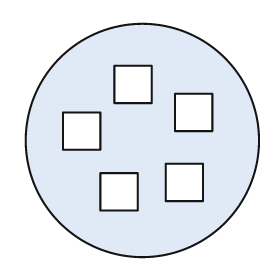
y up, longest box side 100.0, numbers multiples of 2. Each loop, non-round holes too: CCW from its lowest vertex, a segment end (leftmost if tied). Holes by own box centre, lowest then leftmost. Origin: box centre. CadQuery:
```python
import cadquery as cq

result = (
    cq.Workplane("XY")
    .moveTo(0.0, 0.0)
    .circle(50.0)
    .moveTo(-18.0, -30.0)
    .lineTo(-2.0, -30.0)
    .lineTo(-2.0, -14.0)
    .lineTo(-18.0, -14.0)
    .close()
    .moveTo(10.0, -26.0)
    .lineTo(26.0, -26.0)
    .lineTo(26.0, -10.0)
    .lineTo(10.0, -10.0)
    .close()
    .moveTo(-34.0, -4.0)
    .lineTo(-18.0, -4.0)
    .lineTo(-18.0, 12.0)
    .lineTo(-34.0, 12.0)
    .close()
    .moveTo(14.0, 4.0)
    .lineTo(30.0, 4.0)
    .lineTo(30.0, 20.0)
    .lineTo(14.0, 20.0)
    .close()
    .moveTo(-12.0, 16.0)
    .lineTo(4.0, 16.0)
    .lineTo(4.0, 32.0)
    .lineTo(-12.0, 32.0)
    .close()
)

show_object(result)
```